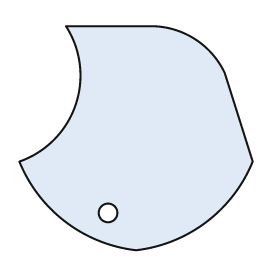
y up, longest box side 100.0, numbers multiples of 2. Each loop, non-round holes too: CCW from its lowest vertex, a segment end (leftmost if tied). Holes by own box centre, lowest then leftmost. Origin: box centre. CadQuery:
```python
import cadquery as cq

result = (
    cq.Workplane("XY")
    .moveTo(0.0, -48.0)
    .threePointArc((30.0, -36.0), (50.0, -10.0))
    .lineTo(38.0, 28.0)
    .threePointArc((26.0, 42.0), (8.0, 48.0))
    .lineTo(-30.0, 48.0)
    .threePointArc((-26.0, 14.0), (-50.0, -10.0))
    .threePointArc((-30.0, -36.0), (0.0, -48.0))
    .close()
    .moveTo(-12.0, -32.0)
    .circle(4.0)
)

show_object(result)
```